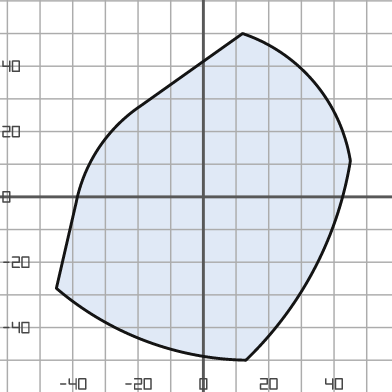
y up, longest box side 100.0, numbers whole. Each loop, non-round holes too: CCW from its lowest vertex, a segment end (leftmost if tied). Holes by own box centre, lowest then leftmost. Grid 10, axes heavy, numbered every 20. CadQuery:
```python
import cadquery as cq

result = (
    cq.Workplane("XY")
    .moveTo(13.0, -50.0)
    .threePointArc((34.0, -22.0), (45.0, 11.0))
    .threePointArc((34.0, 35.0), (12.0, 50.0))
    .lineTo(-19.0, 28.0)
    .threePointArc((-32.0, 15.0), (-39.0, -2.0))
    .lineTo(-45.0, -28.0)
    .threePointArc((-18.0, -44.0), (13.0, -50.0))
    .close()
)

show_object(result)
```